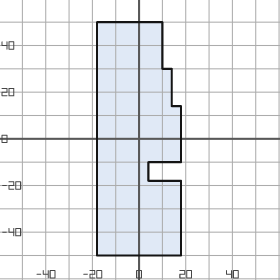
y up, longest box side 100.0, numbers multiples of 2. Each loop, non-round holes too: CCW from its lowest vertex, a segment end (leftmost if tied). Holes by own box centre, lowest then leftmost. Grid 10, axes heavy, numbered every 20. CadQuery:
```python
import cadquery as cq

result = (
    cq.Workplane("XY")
    .moveTo(-18.0, -50.0)
    .lineTo(18.0, -50.0)
    .lineTo(18.0, -18.0)
    .lineTo(4.0, -18.0)
    .lineTo(4.0, -10.0)
    .lineTo(18.0, -10.0)
    .lineTo(18.0, 14.0)
    .lineTo(14.0, 14.0)
    .lineTo(14.0, 30.0)
    .lineTo(10.0, 30.0)
    .lineTo(10.0, 50.0)
    .lineTo(-18.0, 50.0)
    .close()
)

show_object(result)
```